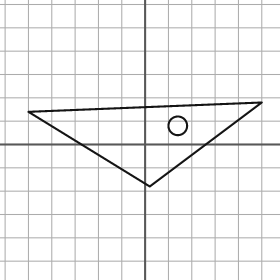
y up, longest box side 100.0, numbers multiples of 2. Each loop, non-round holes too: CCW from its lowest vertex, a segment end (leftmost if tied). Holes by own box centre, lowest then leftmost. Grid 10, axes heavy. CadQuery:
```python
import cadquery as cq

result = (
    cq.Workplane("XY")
    .moveTo(2.0, -18.0)
    .lineTo(50.0, 18.0)
    .lineTo(-50.0, 14.0)
    .close()
    .moveTo(14.0, 8.0)
    .circle(4.0)
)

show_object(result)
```